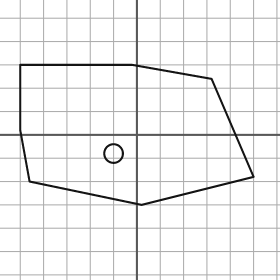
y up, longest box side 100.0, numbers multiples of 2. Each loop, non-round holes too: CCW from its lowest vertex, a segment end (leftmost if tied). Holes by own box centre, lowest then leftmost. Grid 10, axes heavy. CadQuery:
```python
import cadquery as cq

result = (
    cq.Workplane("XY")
    .moveTo(2.0, -30.0)
    .lineTo(50.0, -18.0)
    .lineTo(32.0, 24.0)
    .lineTo(-2.0, 30.0)
    .lineTo(-50.0, 30.0)
    .lineTo(-50.0, 2.0)
    .lineTo(-46.0, -20.0)
    .close()
    .moveTo(-10.0, -8.0)
    .circle(4.0)
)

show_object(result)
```